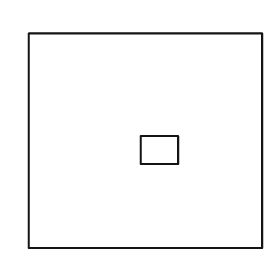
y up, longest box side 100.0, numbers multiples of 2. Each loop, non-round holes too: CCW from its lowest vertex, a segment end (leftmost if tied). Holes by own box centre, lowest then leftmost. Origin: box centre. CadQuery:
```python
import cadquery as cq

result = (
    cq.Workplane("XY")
    .moveTo(-50.0, -46.0)
    .lineTo(50.0, -46.0)
    .lineTo(50.0, 46.0)
    .lineTo(-50.0, 46.0)
    .close()
    .moveTo(-2.0, -10.0)
    .lineTo(14.0, -10.0)
    .lineTo(14.0, 2.0)
    .lineTo(-2.0, 2.0)
    .close()
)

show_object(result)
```